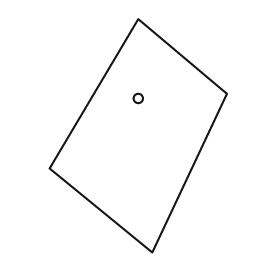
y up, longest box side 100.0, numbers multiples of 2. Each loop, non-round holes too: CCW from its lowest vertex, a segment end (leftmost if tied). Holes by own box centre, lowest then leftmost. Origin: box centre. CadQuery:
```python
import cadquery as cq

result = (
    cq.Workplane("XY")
    .moveTo(6.0, -50.0)
    .lineTo(38.0, 18.0)
    .lineTo(0.0, 50.0)
    .lineTo(-38.0, -14.0)
    .close()
    .moveTo(0.0, 16.0)
    .circle(2.0)
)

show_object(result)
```